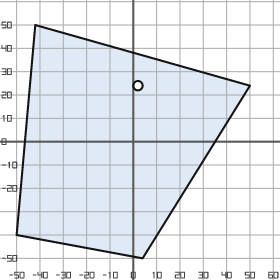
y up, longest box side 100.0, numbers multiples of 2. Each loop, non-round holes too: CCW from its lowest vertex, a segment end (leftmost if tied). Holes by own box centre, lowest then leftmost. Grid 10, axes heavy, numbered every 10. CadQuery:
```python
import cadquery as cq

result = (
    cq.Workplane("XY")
    .moveTo(4.0, -50.0)
    .lineTo(50.0, 24.0)
    .lineTo(-42.0, 50.0)
    .lineTo(-50.0, -40.0)
    .close()
    .moveTo(2.0, 24.0)
    .circle(2.0)
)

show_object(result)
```